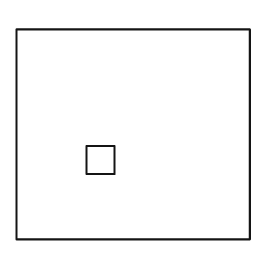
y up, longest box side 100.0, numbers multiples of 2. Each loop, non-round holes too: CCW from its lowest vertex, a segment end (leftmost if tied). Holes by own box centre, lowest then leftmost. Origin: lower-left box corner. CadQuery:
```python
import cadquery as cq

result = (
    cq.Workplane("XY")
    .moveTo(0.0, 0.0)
    .lineTo(100.0, 0.0)
    .lineTo(100.0, 90.0)
    .lineTo(0.0, 90.0)
    .close()
    .moveTo(30.0, 28.0)
    .lineTo(42.0, 28.0)
    .lineTo(42.0, 40.0)
    .lineTo(30.0, 40.0)
    .close()
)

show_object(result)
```